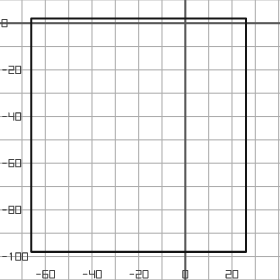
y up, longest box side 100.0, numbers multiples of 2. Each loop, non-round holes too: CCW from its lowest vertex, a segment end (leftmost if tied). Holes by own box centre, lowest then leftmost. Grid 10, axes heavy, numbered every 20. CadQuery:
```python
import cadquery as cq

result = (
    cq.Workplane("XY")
    .moveTo(-66.0, -98.0)
    .lineTo(26.0, -98.0)
    .lineTo(26.0, 2.0)
    .lineTo(-66.0, 2.0)
    .close()
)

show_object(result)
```